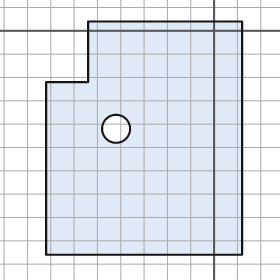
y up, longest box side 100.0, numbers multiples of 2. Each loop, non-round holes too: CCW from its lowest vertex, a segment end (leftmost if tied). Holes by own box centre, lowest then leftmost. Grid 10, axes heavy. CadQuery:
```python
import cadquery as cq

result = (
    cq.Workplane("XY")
    .moveTo(-72.0, -96.0)
    .lineTo(12.0, -96.0)
    .lineTo(12.0, 4.0)
    .lineTo(-54.0, 4.0)
    .lineTo(-54.0, -22.0)
    .lineTo(-72.0, -22.0)
    .close()
    .moveTo(-42.0, -42.0)
    .circle(6.0)
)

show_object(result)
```